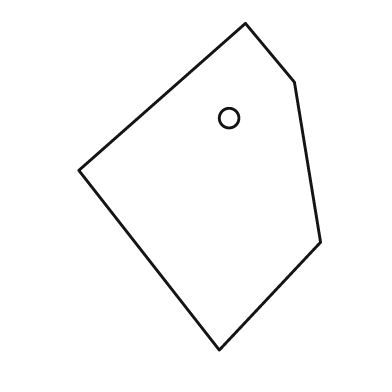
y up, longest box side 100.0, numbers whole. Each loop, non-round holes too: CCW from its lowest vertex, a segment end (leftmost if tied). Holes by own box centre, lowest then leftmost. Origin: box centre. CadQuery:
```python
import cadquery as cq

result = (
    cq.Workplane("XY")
    .moveTo(6.0, -50.0)
    .lineTo(37.0, -17.0)
    .lineTo(29.0, 32.0)
    .lineTo(14.0, 50.0)
    .lineTo(-37.0, 5.0)
    .close()
    .moveTo(9.0, 21.0)
    .circle(3.0)
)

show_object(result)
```